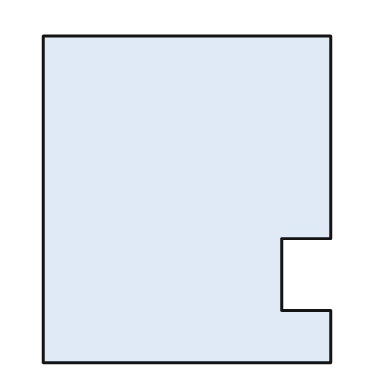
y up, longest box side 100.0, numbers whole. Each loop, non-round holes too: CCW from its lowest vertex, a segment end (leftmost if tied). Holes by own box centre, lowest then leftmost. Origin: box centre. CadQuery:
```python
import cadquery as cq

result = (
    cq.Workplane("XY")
    .moveTo(-44.0, -50.0)
    .lineTo(44.0, -50.0)
    .lineTo(44.0, -34.0)
    .lineTo(29.0, -34.0)
    .lineTo(29.0, -12.0)
    .lineTo(44.0, -12.0)
    .lineTo(44.0, 50.0)
    .lineTo(-44.0, 50.0)
    .close()
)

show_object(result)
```